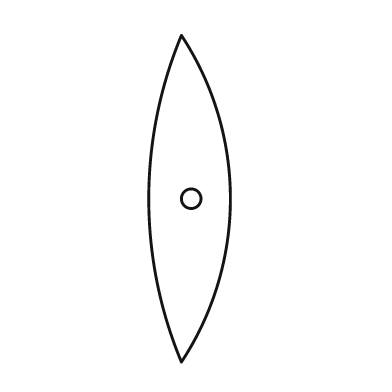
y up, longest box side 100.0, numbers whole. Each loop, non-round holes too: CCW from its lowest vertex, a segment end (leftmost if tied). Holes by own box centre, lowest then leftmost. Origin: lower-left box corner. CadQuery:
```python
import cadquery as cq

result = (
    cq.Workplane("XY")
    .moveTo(10.0, 0.0)
    .threePointArc((25.0, 50.0), (10.0, 100.0))
    .threePointArc((0.0, 50.0), (10.0, 0.0))
    .close()
    .moveTo(13.0, 50.0)
    .circle(3.0)
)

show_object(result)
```